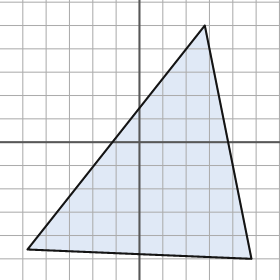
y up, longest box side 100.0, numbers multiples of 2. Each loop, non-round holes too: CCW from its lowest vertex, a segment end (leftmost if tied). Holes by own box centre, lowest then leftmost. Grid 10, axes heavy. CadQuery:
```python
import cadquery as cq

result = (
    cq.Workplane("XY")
    .moveTo(48.0, -50.0)
    .lineTo(28.0, 50.0)
    .lineTo(-48.0, -46.0)
    .close()
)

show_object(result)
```